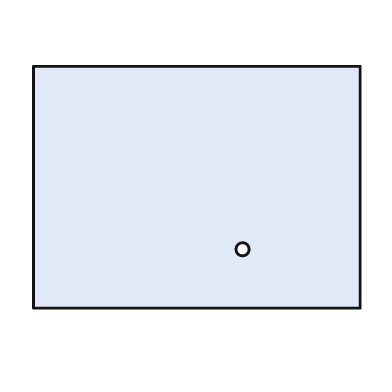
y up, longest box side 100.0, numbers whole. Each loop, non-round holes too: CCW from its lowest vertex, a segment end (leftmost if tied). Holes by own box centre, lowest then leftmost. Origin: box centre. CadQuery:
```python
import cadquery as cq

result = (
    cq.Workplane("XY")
    .moveTo(-50.0, -37.0)
    .lineTo(50.0, -37.0)
    .lineTo(50.0, 37.0)
    .lineTo(-50.0, 37.0)
    .close()
    .moveTo(14.0, -19.0)
    .circle(2.0)
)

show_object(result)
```